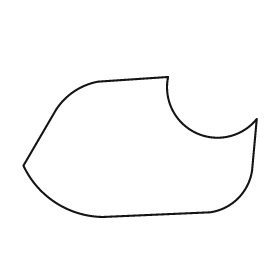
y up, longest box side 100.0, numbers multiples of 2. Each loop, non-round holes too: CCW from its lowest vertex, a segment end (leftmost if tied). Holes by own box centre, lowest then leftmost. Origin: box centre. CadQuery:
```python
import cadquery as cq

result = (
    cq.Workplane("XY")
    .moveTo(-16.0, -30.0)
    .lineTo(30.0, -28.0)
    .threePointArc((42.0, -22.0), (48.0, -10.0))
    .lineTo(50.0, 12.0)
    .threePointArc((24.0, 6.0), (12.0, 30.0))
    .lineTo(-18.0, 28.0)
    .threePointArc((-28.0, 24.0), (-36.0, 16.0))
    .lineTo(-50.0, -8.0)
    .threePointArc((-36.0, -24.0), (-16.0, -30.0))
    .close()
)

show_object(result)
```